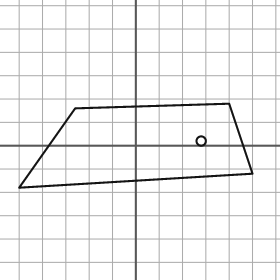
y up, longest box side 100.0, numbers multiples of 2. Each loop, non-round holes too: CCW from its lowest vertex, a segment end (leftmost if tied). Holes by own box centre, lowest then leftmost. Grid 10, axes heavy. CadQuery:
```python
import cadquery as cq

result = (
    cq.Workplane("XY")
    .moveTo(-50.0, -18.0)
    .lineTo(50.0, -12.0)
    .lineTo(40.0, 18.0)
    .lineTo(-26.0, 16.0)
    .close()
    .moveTo(28.0, 2.0)
    .circle(2.0)
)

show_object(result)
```